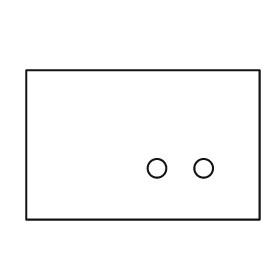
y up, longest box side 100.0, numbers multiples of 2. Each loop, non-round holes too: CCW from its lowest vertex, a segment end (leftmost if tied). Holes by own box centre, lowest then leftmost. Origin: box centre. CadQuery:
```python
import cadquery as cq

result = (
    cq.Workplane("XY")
    .moveTo(-50.0, -32.0)
    .lineTo(50.0, -32.0)
    .lineTo(50.0, 32.0)
    .lineTo(-50.0, 32.0)
    .close()
    .moveTo(6.0, -10.0)
    .circle(4.0)
    .moveTo(26.0, -10.0)
    .circle(4.0)
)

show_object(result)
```